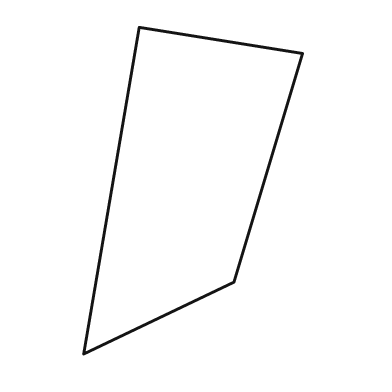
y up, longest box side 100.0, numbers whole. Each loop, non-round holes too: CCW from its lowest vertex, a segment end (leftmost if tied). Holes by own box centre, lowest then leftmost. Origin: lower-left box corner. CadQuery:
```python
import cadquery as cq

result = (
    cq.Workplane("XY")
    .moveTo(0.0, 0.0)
    .lineTo(46.0, 22.0)
    .lineTo(67.0, 92.0)
    .lineTo(17.0, 100.0)
    .close()
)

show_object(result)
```